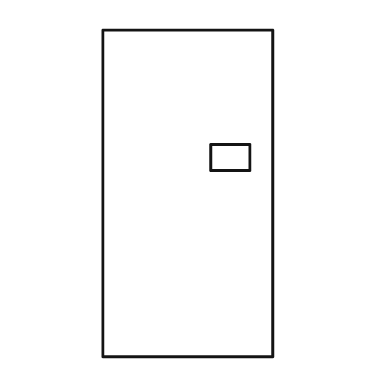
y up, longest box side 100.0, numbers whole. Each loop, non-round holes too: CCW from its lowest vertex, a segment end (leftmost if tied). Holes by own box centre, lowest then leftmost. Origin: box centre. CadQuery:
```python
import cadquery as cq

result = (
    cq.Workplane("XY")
    .moveTo(-26.0, -50.0)
    .lineTo(26.0, -50.0)
    .lineTo(26.0, 50.0)
    .lineTo(-26.0, 50.0)
    .close()
    .moveTo(7.0, 7.0)
    .lineTo(19.0, 7.0)
    .lineTo(19.0, 15.0)
    .lineTo(7.0, 15.0)
    .close()
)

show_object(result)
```